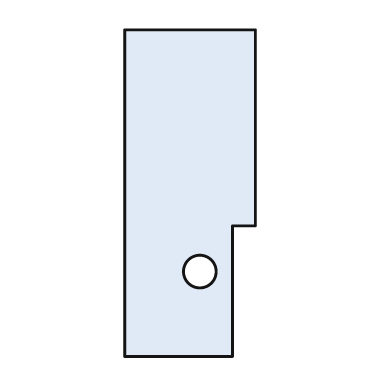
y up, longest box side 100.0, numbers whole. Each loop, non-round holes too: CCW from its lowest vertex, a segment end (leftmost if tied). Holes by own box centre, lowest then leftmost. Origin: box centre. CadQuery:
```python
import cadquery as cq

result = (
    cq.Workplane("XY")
    .moveTo(-20.0, -50.0)
    .lineTo(13.0, -50.0)
    .lineTo(13.0, -10.0)
    .lineTo(20.0, -10.0)
    .lineTo(20.0, 50.0)
    .lineTo(-20.0, 50.0)
    .close()
    .moveTo(3.0, -24.0)
    .circle(5.0)
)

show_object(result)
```